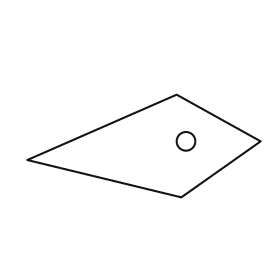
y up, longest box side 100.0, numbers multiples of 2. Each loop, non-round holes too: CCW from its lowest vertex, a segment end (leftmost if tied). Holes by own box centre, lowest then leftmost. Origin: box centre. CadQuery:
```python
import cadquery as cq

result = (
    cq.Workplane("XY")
    .moveTo(16.0, -22.0)
    .lineTo(50.0, 2.0)
    .lineTo(14.0, 22.0)
    .lineTo(-50.0, -6.0)
    .close()
    .moveTo(18.0, 2.0)
    .circle(4.0)
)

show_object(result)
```